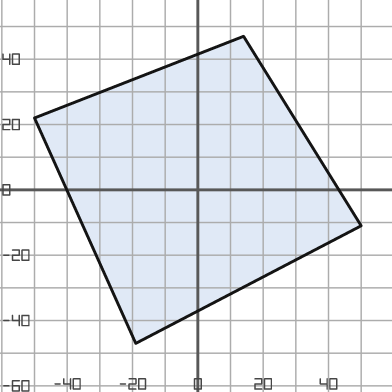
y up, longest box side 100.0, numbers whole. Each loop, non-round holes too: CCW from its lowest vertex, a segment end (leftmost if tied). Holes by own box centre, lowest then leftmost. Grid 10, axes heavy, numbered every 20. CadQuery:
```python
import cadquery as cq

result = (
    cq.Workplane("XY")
    .moveTo(-19.0, -47.0)
    .lineTo(50.0, -11.0)
    .lineTo(14.0, 47.0)
    .lineTo(-50.0, 22.0)
    .close()
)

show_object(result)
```